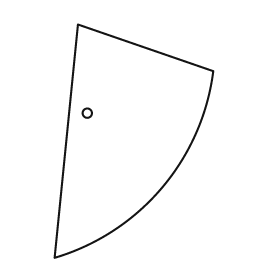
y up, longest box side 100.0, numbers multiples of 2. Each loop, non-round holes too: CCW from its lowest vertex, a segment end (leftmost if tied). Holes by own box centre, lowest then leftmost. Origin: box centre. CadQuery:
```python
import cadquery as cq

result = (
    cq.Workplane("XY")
    .moveTo(-34.0, -50.0)
    .threePointArc((12.0, -20.0), (34.0, 30.0))
    .lineTo(-24.0, 50.0)
    .close()
    .moveTo(-20.0, 12.0)
    .circle(2.0)
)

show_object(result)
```